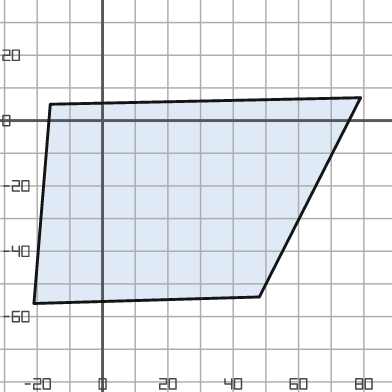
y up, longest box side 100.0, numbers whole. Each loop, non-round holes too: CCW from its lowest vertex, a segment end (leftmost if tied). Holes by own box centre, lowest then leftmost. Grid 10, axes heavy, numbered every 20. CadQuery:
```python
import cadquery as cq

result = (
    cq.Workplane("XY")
    .moveTo(-21.0, -56.0)
    .lineTo(48.0, -54.0)
    .lineTo(79.0, 7.0)
    .lineTo(-16.0, 5.0)
    .close()
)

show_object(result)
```